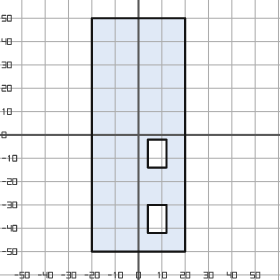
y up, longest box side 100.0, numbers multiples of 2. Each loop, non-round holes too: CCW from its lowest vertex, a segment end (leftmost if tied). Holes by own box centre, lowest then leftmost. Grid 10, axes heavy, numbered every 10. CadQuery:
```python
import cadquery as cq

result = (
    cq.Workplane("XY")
    .moveTo(-20.0, -50.0)
    .lineTo(20.0, -50.0)
    .lineTo(20.0, 50.0)
    .lineTo(-20.0, 50.0)
    .close()
    .moveTo(4.0, -42.0)
    .lineTo(12.0, -42.0)
    .lineTo(12.0, -30.0)
    .lineTo(4.0, -30.0)
    .close()
    .moveTo(4.0, -14.0)
    .lineTo(12.0, -14.0)
    .lineTo(12.0, -2.0)
    .lineTo(4.0, -2.0)
    .close()
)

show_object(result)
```